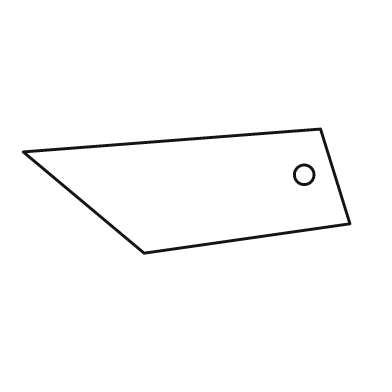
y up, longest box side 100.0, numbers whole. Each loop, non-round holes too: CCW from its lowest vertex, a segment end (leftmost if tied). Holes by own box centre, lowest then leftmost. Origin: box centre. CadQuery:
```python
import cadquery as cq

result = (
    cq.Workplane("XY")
    .moveTo(-13.0, -19.0)
    .lineTo(50.0, -10.0)
    .lineTo(41.0, 19.0)
    .lineTo(-50.0, 12.0)
    .close()
    .moveTo(36.0, 5.0)
    .circle(3.0)
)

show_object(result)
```